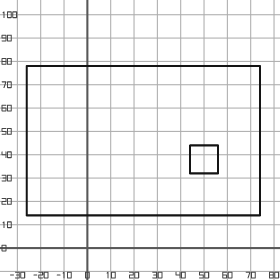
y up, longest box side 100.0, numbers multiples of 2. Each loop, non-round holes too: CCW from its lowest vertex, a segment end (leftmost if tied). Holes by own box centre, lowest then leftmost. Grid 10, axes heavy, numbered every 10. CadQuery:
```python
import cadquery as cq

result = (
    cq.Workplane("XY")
    .moveTo(-26.0, 14.0)
    .lineTo(74.0, 14.0)
    .lineTo(74.0, 78.0)
    .lineTo(-26.0, 78.0)
    .close()
    .moveTo(44.0, 32.0)
    .lineTo(56.0, 32.0)
    .lineTo(56.0, 44.0)
    .lineTo(44.0, 44.0)
    .close()
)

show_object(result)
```